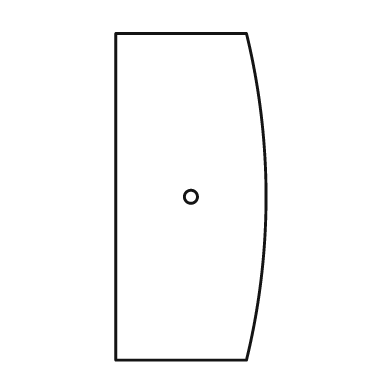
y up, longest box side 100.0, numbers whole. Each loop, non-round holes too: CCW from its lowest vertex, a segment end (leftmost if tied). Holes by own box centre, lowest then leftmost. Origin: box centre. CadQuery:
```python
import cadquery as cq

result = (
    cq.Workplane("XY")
    .moveTo(-23.0, -50.0)
    .lineTo(17.0, -50.0)
    .threePointArc((23.0, 0.0), (17.0, 50.0))
    .lineTo(-23.0, 50.0)
    .close()
    .moveTo(0.0, 0.0)
    .circle(2.0)
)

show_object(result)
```